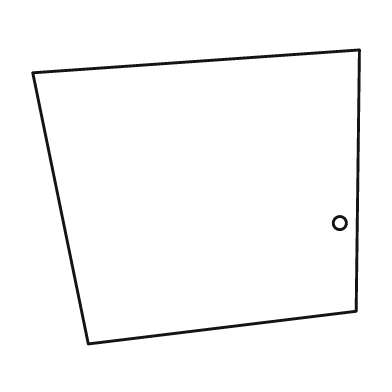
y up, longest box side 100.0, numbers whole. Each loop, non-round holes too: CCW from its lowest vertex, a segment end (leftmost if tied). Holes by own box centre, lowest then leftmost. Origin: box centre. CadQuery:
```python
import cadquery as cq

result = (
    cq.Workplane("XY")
    .moveTo(-33.0, -45.0)
    .lineTo(49.0, -35.0)
    .lineTo(50.0, 45.0)
    .lineTo(-50.0, 38.0)
    .close()
    .moveTo(44.0, -8.0)
    .circle(2.0)
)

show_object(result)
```